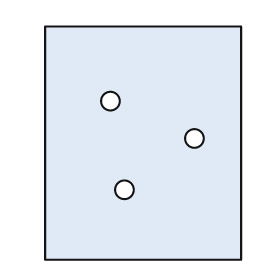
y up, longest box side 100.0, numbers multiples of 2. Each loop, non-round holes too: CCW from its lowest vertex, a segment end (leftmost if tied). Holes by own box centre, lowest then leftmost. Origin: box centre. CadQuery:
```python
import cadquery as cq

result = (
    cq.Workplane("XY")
    .moveTo(-42.0, -50.0)
    .lineTo(42.0, -50.0)
    .lineTo(42.0, 50.0)
    .lineTo(-42.0, 50.0)
    .close()
    .moveTo(-8.0, -20.0)
    .circle(4.0)
    .moveTo(22.0, 2.0)
    .circle(4.0)
    .moveTo(-14.0, 18.0)
    .circle(4.0)
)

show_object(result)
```